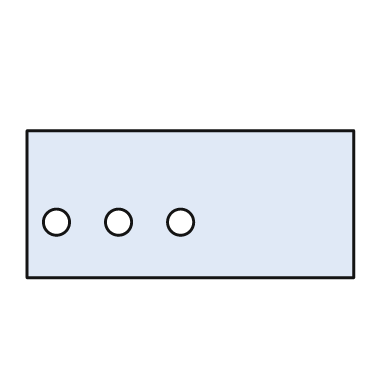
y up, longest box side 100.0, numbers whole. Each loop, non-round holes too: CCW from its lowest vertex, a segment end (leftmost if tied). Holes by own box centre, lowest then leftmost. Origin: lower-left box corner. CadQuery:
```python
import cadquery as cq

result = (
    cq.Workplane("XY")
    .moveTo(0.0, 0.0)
    .lineTo(100.0, 0.0)
    .lineTo(100.0, 45.0)
    .lineTo(0.0, 45.0)
    .close()
    .moveTo(9.0, 17.0)
    .circle(4.0)
    .moveTo(28.0, 17.0)
    .circle(4.0)
    .moveTo(47.0, 17.0)
    .circle(4.0)
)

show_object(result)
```